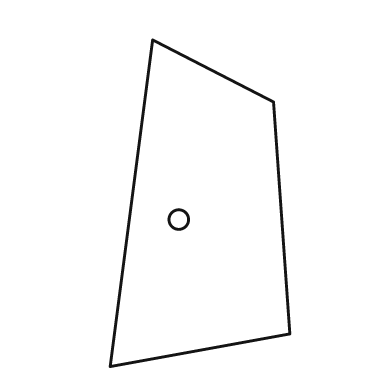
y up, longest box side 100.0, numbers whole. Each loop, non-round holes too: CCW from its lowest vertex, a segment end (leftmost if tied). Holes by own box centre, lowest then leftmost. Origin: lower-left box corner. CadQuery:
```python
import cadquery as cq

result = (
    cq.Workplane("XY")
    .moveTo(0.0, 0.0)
    .lineTo(55.0, 10.0)
    .lineTo(50.0, 81.0)
    .lineTo(13.0, 100.0)
    .close()
    .moveTo(21.0, 45.0)
    .circle(3.0)
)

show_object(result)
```